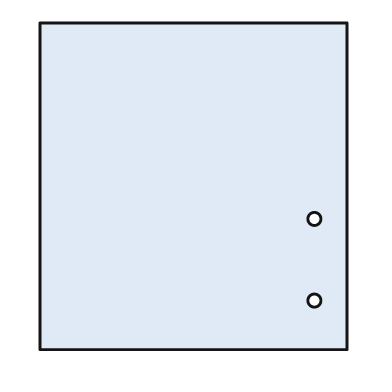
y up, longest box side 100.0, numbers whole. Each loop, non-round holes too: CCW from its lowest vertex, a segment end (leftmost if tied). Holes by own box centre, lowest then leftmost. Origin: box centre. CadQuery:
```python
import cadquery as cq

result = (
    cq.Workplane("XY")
    .moveTo(-47.0, -50.0)
    .lineTo(47.0, -50.0)
    .lineTo(47.0, 50.0)
    .lineTo(-47.0, 50.0)
    .close()
    .moveTo(37.0, -35.0)
    .circle(2.0)
    .moveTo(37.0, -10.0)
    .circle(2.0)
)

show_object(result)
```